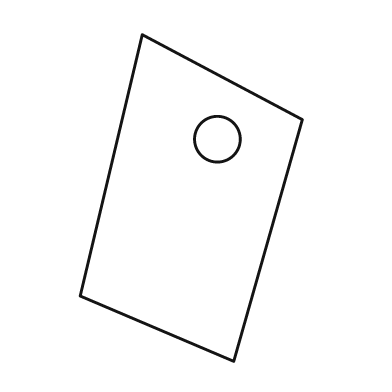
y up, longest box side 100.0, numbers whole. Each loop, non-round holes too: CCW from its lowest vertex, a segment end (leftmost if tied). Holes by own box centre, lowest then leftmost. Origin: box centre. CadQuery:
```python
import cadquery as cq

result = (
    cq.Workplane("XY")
    .moveTo(13.0, -50.0)
    .lineTo(34.0, 24.0)
    .lineTo(-15.0, 50.0)
    .lineTo(-34.0, -30.0)
    .close()
    .moveTo(8.0, 18.0)
    .circle(7.0)
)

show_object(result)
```